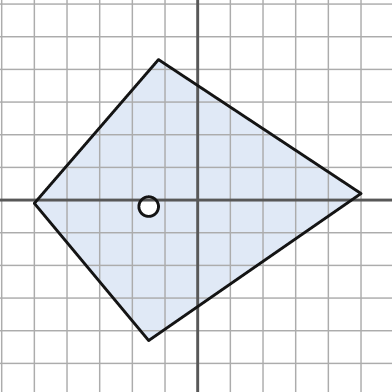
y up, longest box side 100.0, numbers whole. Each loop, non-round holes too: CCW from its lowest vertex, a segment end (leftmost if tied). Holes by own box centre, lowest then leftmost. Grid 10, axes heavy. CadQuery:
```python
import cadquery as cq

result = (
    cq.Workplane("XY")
    .moveTo(-15.0, -43.0)
    .lineTo(50.0, 2.0)
    .lineTo(-12.0, 43.0)
    .lineTo(-50.0, -1.0)
    .close()
    .moveTo(-15.0, -2.0)
    .circle(3.0)
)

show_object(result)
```